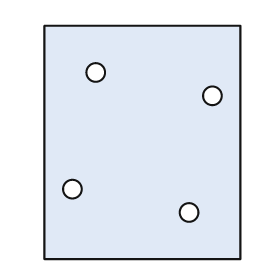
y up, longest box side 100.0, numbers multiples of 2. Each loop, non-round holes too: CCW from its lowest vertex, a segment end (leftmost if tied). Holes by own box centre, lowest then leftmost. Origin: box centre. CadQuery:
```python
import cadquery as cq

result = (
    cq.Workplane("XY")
    .moveTo(-42.0, -50.0)
    .lineTo(42.0, -50.0)
    .lineTo(42.0, 50.0)
    .lineTo(-42.0, 50.0)
    .close()
    .moveTo(20.0, -30.0)
    .circle(4.0)
    .moveTo(-30.0, -20.0)
    .circle(4.0)
    .moveTo(30.0, 20.0)
    .circle(4.0)
    .moveTo(-20.0, 30.0)
    .circle(4.0)
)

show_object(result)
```